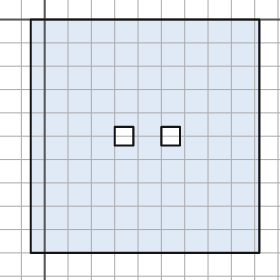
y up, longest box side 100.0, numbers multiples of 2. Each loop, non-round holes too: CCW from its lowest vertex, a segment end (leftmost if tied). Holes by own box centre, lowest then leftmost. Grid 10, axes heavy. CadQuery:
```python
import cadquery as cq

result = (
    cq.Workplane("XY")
    .moveTo(-6.0, -100.0)
    .lineTo(92.0, -100.0)
    .lineTo(92.0, 0.0)
    .lineTo(-6.0, 0.0)
    .close()
    .moveTo(30.0, -54.0)
    .lineTo(38.0, -54.0)
    .lineTo(38.0, -46.0)
    .lineTo(30.0, -46.0)
    .close()
    .moveTo(50.0, -54.0)
    .lineTo(58.0, -54.0)
    .lineTo(58.0, -46.0)
    .lineTo(50.0, -46.0)
    .close()
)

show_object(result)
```